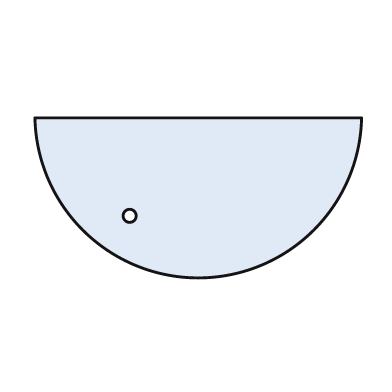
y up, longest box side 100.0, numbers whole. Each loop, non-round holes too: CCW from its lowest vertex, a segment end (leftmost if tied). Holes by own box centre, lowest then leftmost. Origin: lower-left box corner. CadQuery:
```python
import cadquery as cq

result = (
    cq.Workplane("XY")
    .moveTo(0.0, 49.0)
    .threePointArc((50.0, 0.0), (100.0, 49.0))
    .close()
    .moveTo(29.0, 19.0)
    .circle(2.0)
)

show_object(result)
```